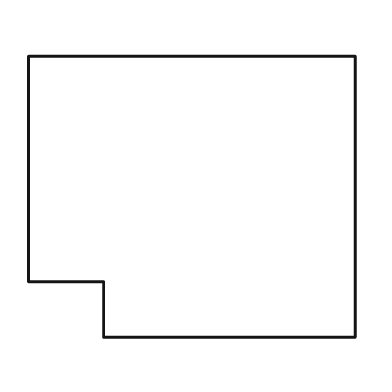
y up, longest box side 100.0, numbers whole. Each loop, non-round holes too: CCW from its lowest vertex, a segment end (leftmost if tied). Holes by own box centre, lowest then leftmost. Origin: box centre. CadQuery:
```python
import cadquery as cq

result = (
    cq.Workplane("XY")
    .moveTo(-27.0, -43.0)
    .lineTo(50.0, -43.0)
    .lineTo(50.0, 43.0)
    .lineTo(-50.0, 43.0)
    .lineTo(-50.0, -26.0)
    .lineTo(-27.0, -26.0)
    .close()
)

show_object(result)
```